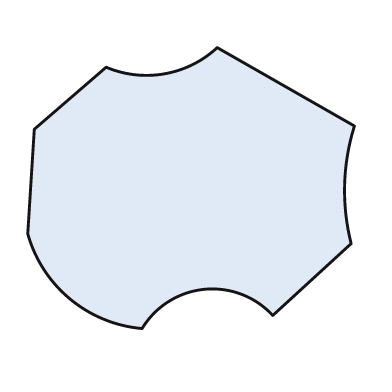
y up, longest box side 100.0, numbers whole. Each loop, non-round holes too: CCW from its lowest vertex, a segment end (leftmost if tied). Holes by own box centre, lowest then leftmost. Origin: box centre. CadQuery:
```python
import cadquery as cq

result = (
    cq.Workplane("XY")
    .moveTo(-15.0, -43.0)
    .threePointArc((4.0, -31.0), (25.0, -39.0))
    .lineTo(49.0, -17.0)
    .threePointArc((47.0, 1.0), (50.0, 19.0))
    .lineTo(8.0, 43.0)
    .threePointArc((-8.0, 35.0), (-26.0, 37.0))
    .lineTo(-48.0, 18.0)
    .lineTo(-50.0, -14.0)
    .threePointArc((-37.0, -34.0), (-15.0, -43.0))
    .close()
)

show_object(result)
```